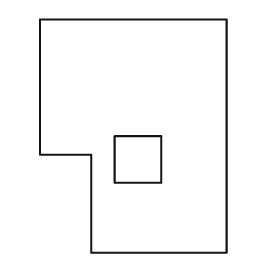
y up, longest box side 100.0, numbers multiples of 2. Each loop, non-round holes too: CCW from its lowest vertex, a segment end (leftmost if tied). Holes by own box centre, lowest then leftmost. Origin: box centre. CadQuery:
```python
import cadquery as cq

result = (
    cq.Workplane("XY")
    .moveTo(-18.0, -50.0)
    .lineTo(40.0, -50.0)
    .lineTo(40.0, 50.0)
    .lineTo(-40.0, 50.0)
    .lineTo(-40.0, -8.0)
    .lineTo(-18.0, -8.0)
    .close()
    .moveTo(-8.0, -20.0)
    .lineTo(12.0, -20.0)
    .lineTo(12.0, 0.0)
    .lineTo(-8.0, 0.0)
    .close()
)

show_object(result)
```